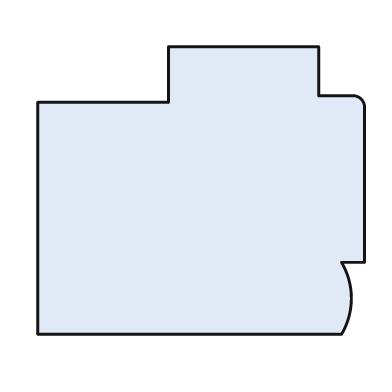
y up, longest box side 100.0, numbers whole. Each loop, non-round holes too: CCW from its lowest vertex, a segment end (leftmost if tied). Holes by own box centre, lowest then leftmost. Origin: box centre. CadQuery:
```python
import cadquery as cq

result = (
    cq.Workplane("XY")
    .moveTo(-50.0, -44.0)
    .lineTo(43.0, -44.0)
    .threePointArc((46.0, -33.0), (43.0, -22.0))
    .lineTo(50.0, -22.0)
    .lineTo(50.0, 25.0)
    .threePointArc((49.0, 28.0), (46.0, 29.0))
    .lineTo(36.0, 29.0)
    .lineTo(36.0, 44.0)
    .lineTo(-10.0, 44.0)
    .lineTo(-10.0, 27.0)
    .lineTo(-50.0, 27.0)
    .close()
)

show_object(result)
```